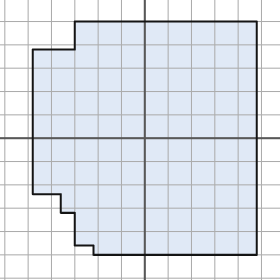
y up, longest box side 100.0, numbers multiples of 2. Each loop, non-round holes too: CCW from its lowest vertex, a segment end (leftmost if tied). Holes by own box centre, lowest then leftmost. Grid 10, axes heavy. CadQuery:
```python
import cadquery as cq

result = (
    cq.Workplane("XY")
    .moveTo(-22.0, -50.0)
    .lineTo(48.0, -50.0)
    .lineTo(48.0, 50.0)
    .lineTo(-30.0, 50.0)
    .lineTo(-30.0, 38.0)
    .lineTo(-48.0, 38.0)
    .lineTo(-48.0, -24.0)
    .lineTo(-36.0, -24.0)
    .lineTo(-36.0, -32.0)
    .lineTo(-30.0, -32.0)
    .lineTo(-30.0, -46.0)
    .lineTo(-22.0, -46.0)
    .close()
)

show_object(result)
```